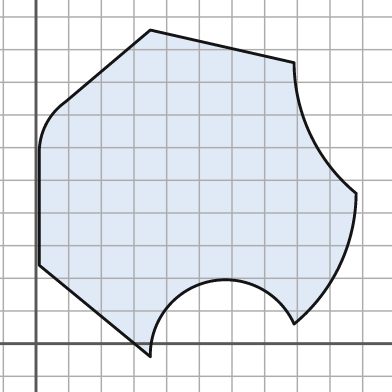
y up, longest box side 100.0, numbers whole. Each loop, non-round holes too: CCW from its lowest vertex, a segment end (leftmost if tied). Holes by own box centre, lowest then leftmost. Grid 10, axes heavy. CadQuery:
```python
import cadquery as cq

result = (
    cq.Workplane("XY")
    .moveTo(35.0, -4.0)
    .threePointArc((53.0, 19.0), (79.0, 6.0))
    .threePointArc((93.0, 24.0), (98.0, 46.0))
    .threePointArc((84.0, 64.0), (79.0, 86.0))
    .lineTo(35.0, 96.0)
    .lineTo(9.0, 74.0)
    .threePointArc((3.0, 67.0), (1.0, 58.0))
    .lineTo(1.0, 24.0)
    .close()
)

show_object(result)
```